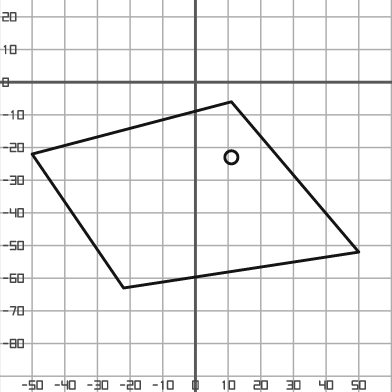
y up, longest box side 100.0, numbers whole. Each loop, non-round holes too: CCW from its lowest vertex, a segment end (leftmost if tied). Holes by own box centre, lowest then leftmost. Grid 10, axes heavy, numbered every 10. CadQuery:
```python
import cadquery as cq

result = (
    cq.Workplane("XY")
    .moveTo(-22.0, -63.0)
    .lineTo(50.0, -52.0)
    .lineTo(11.0, -6.0)
    .lineTo(-50.0, -22.0)
    .close()
    .moveTo(11.0, -23.0)
    .circle(2.0)
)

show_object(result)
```